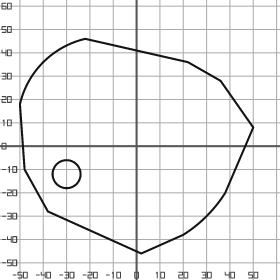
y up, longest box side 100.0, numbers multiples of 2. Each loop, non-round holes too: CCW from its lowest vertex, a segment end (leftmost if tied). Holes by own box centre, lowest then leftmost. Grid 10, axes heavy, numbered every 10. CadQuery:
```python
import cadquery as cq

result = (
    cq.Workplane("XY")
    .moveTo(2.0, -46.0)
    .lineTo(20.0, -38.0)
    .threePointArc((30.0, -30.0), (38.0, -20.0))
    .lineTo(50.0, 8.0)
    .lineTo(36.0, 28.0)
    .lineTo(22.0, 36.0)
    .lineTo(-22.0, 46.0)
    .threePointArc((-40.0, 36.0), (-50.0, 18.0))
    .lineTo(-48.0, -10.0)
    .lineTo(-38.0, -28.0)
    .close()
    .moveTo(-30.0, -12.0)
    .circle(6.0)
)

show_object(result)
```